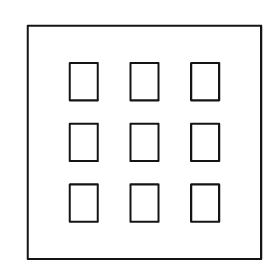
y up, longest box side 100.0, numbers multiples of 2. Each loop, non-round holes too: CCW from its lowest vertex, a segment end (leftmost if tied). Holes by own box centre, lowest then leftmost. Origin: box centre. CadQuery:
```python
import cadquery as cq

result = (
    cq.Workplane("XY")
    .moveTo(-50.0, -50.0)
    .lineTo(50.0, -50.0)
    .lineTo(50.0, 50.0)
    .lineTo(-50.0, 50.0)
    .close()
    .moveTo(-32.0, -34.0)
    .lineTo(-20.0, -34.0)
    .lineTo(-20.0, -18.0)
    .lineTo(-32.0, -18.0)
    .close()
    .moveTo(-6.0, -34.0)
    .lineTo(6.0, -34.0)
    .lineTo(6.0, -18.0)
    .lineTo(-6.0, -18.0)
    .close()
    .moveTo(20.0, -34.0)
    .lineTo(32.0, -34.0)
    .lineTo(32.0, -18.0)
    .lineTo(20.0, -18.0)
    .close()
    .moveTo(-32.0, -8.0)
    .lineTo(-20.0, -8.0)
    .lineTo(-20.0, 8.0)
    .lineTo(-32.0, 8.0)
    .close()
    .moveTo(-6.0, -8.0)
    .lineTo(6.0, -8.0)
    .lineTo(6.0, 8.0)
    .lineTo(-6.0, 8.0)
    .close()
    .moveTo(20.0, -8.0)
    .lineTo(32.0, -8.0)
    .lineTo(32.0, 8.0)
    .lineTo(20.0, 8.0)
    .close()
    .moveTo(-32.0, 18.0)
    .lineTo(-20.0, 18.0)
    .lineTo(-20.0, 34.0)
    .lineTo(-32.0, 34.0)
    .close()
    .moveTo(-6.0, 18.0)
    .lineTo(6.0, 18.0)
    .lineTo(6.0, 34.0)
    .lineTo(-6.0, 34.0)
    .close()
    .moveTo(20.0, 18.0)
    .lineTo(32.0, 18.0)
    .lineTo(32.0, 34.0)
    .lineTo(20.0, 34.0)
    .close()
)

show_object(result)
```